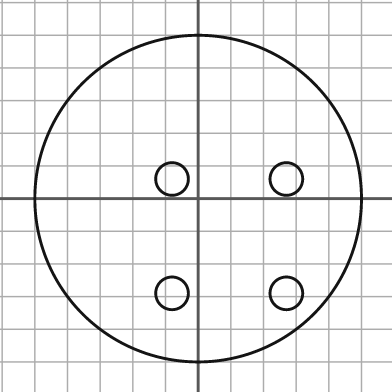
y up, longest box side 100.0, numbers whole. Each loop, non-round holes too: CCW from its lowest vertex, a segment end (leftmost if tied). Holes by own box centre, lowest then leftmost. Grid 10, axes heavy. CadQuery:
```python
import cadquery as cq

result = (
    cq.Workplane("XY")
    .moveTo(0.0, 0.0)
    .circle(50.0)
    .moveTo(-8.0, -29.0)
    .circle(5.0)
    .moveTo(27.0, -29.0)
    .circle(5.0)
    .moveTo(-8.0, 6.0)
    .circle(5.0)
    .moveTo(27.0, 6.0)
    .circle(5.0)
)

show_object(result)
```